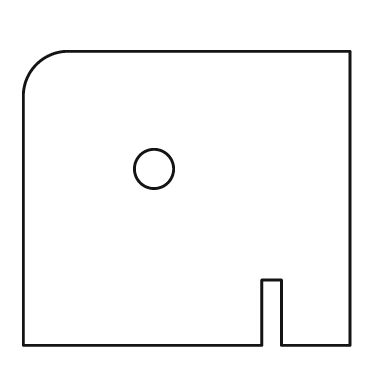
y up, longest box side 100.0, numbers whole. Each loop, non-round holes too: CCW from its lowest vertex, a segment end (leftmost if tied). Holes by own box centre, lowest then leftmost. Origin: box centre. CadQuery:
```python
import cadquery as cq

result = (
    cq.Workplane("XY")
    .moveTo(-50.0, -45.0)
    .lineTo(23.0, -45.0)
    .lineTo(23.0, -25.0)
    .lineTo(29.0, -25.0)
    .lineTo(29.0, -45.0)
    .lineTo(50.0, -45.0)
    .lineTo(50.0, 45.0)
    .lineTo(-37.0, 45.0)
    .threePointArc((-46.0, 41.0), (-50.0, 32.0))
    .close()
    .moveTo(-10.0, 9.0)
    .circle(6.0)
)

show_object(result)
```